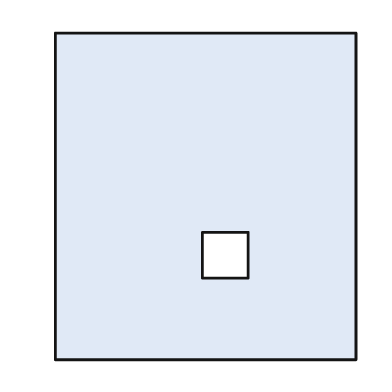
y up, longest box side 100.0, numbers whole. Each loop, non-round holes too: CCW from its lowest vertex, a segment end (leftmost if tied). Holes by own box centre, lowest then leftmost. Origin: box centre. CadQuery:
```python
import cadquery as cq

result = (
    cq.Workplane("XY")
    .moveTo(-46.0, -50.0)
    .lineTo(46.0, -50.0)
    .lineTo(46.0, 50.0)
    .lineTo(-46.0, 50.0)
    .close()
    .moveTo(-1.0, -25.0)
    .lineTo(13.0, -25.0)
    .lineTo(13.0, -11.0)
    .lineTo(-1.0, -11.0)
    .close()
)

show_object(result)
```